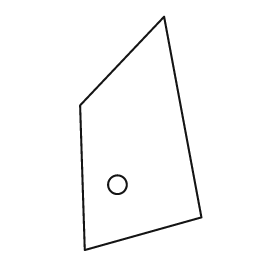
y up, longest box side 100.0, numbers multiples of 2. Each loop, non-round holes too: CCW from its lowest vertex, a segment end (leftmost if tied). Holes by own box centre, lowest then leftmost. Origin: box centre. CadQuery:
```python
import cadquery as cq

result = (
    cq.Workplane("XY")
    .moveTo(-24.0, -50.0)
    .lineTo(26.0, -36.0)
    .lineTo(10.0, 50.0)
    .lineTo(-26.0, 12.0)
    .close()
    .moveTo(-10.0, -22.0)
    .circle(4.0)
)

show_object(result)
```